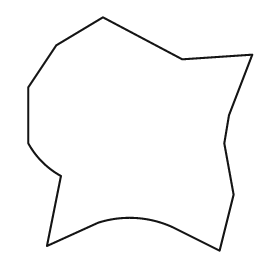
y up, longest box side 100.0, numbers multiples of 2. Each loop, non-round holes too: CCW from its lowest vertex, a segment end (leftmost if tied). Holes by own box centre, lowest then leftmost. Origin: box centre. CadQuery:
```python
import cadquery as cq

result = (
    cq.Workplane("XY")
    .moveTo(34.0, -50.0)
    .lineTo(40.0, -26.0)
    .lineTo(36.0, -4.0)
    .lineTo(38.0, 8.0)
    .lineTo(48.0, 34.0)
    .lineTo(18.0, 32.0)
    .lineTo(-16.0, 50.0)
    .lineTo(-36.0, 38.0)
    .lineTo(-48.0, 20.0)
    .lineTo(-48.0, -4.0)
    .threePointArc((-42.0, -12.0), (-34.0, -18.0))
    .lineTo(-40.0, -48.0)
    .lineTo(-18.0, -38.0)
    .threePointArc((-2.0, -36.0), (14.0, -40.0))
    .close()
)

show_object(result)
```